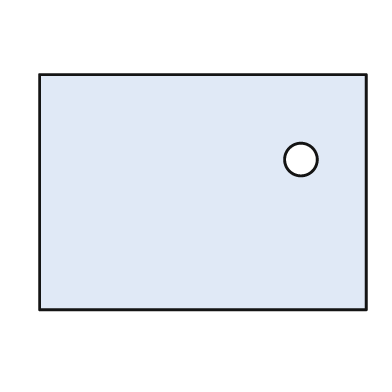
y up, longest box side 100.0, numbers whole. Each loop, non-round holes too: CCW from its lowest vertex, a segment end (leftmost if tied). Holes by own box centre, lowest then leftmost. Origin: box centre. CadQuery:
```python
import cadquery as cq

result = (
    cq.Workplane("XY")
    .moveTo(-50.0, -36.0)
    .lineTo(50.0, -36.0)
    .lineTo(50.0, 36.0)
    .lineTo(-50.0, 36.0)
    .close()
    .moveTo(30.0, 10.0)
    .circle(5.0)
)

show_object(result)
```